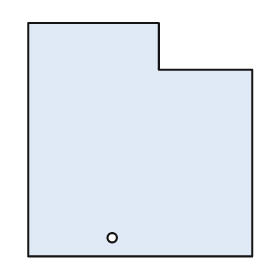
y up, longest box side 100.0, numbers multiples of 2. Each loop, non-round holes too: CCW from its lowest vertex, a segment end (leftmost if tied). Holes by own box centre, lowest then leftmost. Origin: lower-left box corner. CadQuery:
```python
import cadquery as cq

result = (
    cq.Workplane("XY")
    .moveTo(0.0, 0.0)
    .lineTo(96.0, 0.0)
    .lineTo(96.0, 80.0)
    .lineTo(56.0, 80.0)
    .lineTo(56.0, 100.0)
    .lineTo(0.0, 100.0)
    .close()
    .moveTo(36.0, 8.0)
    .circle(2.0)
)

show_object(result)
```